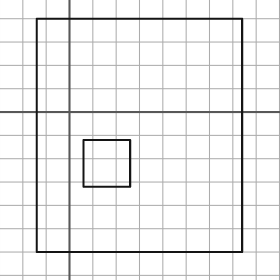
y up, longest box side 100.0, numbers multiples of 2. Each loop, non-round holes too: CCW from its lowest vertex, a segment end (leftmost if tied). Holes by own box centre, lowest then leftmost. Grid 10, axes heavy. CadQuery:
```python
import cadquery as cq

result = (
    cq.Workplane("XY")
    .moveTo(-14.0, -60.0)
    .lineTo(74.0, -60.0)
    .lineTo(74.0, 40.0)
    .lineTo(-14.0, 40.0)
    .close()
    .moveTo(6.0, -32.0)
    .lineTo(26.0, -32.0)
    .lineTo(26.0, -12.0)
    .lineTo(6.0, -12.0)
    .close()
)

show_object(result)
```